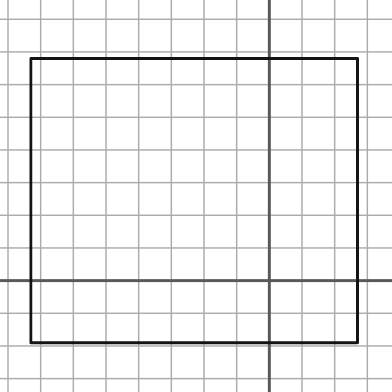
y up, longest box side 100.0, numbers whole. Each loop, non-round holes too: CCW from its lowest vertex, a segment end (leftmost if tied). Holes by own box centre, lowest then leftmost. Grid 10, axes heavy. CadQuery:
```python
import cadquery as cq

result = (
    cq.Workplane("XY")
    .moveTo(-73.0, -19.0)
    .lineTo(27.0, -19.0)
    .lineTo(27.0, 68.0)
    .lineTo(-73.0, 68.0)
    .close()
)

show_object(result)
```